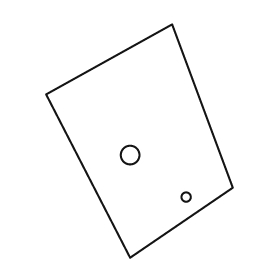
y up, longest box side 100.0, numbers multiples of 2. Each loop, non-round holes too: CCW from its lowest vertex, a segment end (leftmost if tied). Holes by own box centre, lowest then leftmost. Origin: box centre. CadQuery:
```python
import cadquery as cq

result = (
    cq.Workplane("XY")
    .moveTo(-4.0, -50.0)
    .lineTo(40.0, -20.0)
    .lineTo(14.0, 50.0)
    .lineTo(-40.0, 20.0)
    .close()
    .moveTo(20.0, -24.0)
    .circle(2.0)
    .moveTo(-4.0, -6.0)
    .circle(4.0)
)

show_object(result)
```